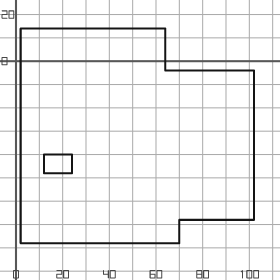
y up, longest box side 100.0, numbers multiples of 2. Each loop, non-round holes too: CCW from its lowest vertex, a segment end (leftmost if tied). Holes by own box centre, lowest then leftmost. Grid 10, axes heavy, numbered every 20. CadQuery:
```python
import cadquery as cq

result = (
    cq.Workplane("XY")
    .moveTo(2.0, -78.0)
    .lineTo(70.0, -78.0)
    .lineTo(70.0, -68.0)
    .lineTo(102.0, -68.0)
    .lineTo(102.0, -4.0)
    .lineTo(64.0, -4.0)
    .lineTo(64.0, 14.0)
    .lineTo(2.0, 14.0)
    .close()
    .moveTo(12.0, -48.0)
    .lineTo(24.0, -48.0)
    .lineTo(24.0, -40.0)
    .lineTo(12.0, -40.0)
    .close()
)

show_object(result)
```